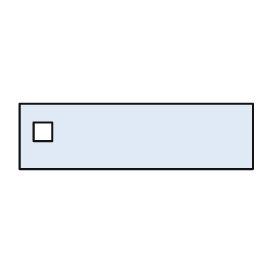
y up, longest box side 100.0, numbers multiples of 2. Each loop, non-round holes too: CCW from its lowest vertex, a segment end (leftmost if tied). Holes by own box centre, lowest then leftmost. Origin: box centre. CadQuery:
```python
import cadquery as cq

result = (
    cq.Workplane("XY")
    .moveTo(-50.0, -14.0)
    .lineTo(50.0, -14.0)
    .lineTo(50.0, 14.0)
    .lineTo(-50.0, 14.0)
    .close()
    .moveTo(-44.0, -2.0)
    .lineTo(-36.0, -2.0)
    .lineTo(-36.0, 6.0)
    .lineTo(-44.0, 6.0)
    .close()
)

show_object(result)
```